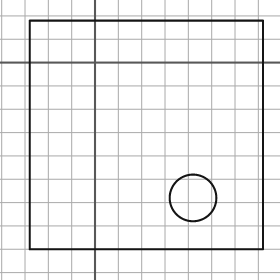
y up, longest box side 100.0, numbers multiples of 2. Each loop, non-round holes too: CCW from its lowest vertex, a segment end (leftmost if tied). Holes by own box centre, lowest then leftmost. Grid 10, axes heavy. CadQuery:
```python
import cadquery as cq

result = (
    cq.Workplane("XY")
    .moveTo(-28.0, -80.0)
    .lineTo(72.0, -80.0)
    .lineTo(72.0, 18.0)
    .lineTo(-28.0, 18.0)
    .close()
    .moveTo(42.0, -58.0)
    .circle(10.0)
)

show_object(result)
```